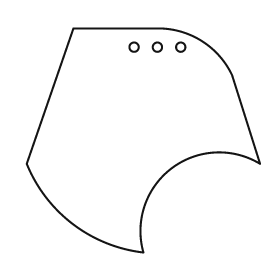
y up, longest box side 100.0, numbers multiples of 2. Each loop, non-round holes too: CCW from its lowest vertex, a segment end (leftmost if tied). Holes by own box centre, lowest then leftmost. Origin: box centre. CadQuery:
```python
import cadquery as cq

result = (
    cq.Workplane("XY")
    .moveTo(0.0, -48.0)
    .threePointArc((12.0, -12.0), (50.0, -10.0))
    .lineTo(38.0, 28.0)
    .threePointArc((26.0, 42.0), (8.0, 48.0))
    .lineTo(-30.0, 48.0)
    .lineTo(-50.0, -10.0)
    .threePointArc((-30.0, -36.0), (0.0, -48.0))
    .close()
    .moveTo(-4.0, 40.0)
    .circle(2.0)
    .moveTo(6.0, 40.0)
    .circle(2.0)
    .moveTo(16.0, 40.0)
    .circle(2.0)
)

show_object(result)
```